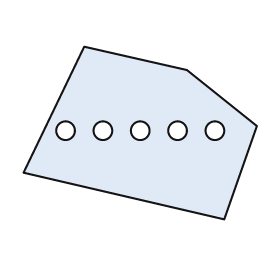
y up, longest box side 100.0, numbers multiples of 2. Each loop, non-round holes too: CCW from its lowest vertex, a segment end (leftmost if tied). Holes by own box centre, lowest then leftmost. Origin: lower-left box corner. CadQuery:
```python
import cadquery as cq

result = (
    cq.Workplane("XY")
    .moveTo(86.0, 0.0)
    .lineTo(100.0, 40.0)
    .lineTo(70.0, 64.0)
    .lineTo(26.0, 74.0)
    .lineTo(0.0, 20.0)
    .close()
    .moveTo(18.0, 38.0)
    .circle(4.0)
    .moveTo(34.0, 38.0)
    .circle(4.0)
    .moveTo(50.0, 38.0)
    .circle(4.0)
    .moveTo(66.0, 38.0)
    .circle(4.0)
    .moveTo(82.0, 38.0)
    .circle(4.0)
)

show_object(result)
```